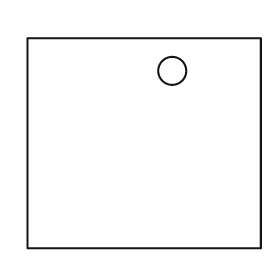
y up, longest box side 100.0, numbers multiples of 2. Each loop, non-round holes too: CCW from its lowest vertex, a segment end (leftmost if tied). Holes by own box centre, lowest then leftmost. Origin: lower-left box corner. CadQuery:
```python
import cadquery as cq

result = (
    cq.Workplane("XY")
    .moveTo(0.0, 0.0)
    .lineTo(100.0, 0.0)
    .lineTo(100.0, 90.0)
    .lineTo(0.0, 90.0)
    .close()
    .moveTo(62.0, 76.0)
    .circle(6.0)
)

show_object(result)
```